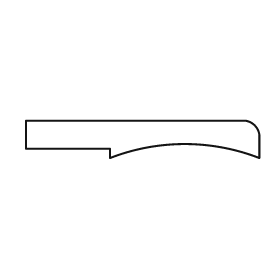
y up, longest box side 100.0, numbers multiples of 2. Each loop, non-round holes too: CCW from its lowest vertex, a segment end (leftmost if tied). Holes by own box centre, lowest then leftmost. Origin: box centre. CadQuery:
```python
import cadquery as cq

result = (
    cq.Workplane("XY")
    .moveTo(-14.0, -8.0)
    .threePointArc((18.0, -2.0), (50.0, -8.0))
    .lineTo(50.0, 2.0)
    .threePointArc((48.0, 6.0), (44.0, 8.0))
    .lineTo(-50.0, 8.0)
    .lineTo(-50.0, -4.0)
    .lineTo(-14.0, -4.0)
    .close()
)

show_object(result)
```